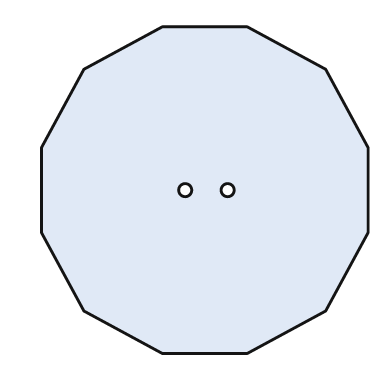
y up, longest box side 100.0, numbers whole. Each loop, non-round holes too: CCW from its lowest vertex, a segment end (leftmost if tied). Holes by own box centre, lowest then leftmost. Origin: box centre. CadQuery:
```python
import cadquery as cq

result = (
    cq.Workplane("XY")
    .moveTo(-13.0, -50.0)
    .lineTo(13.0, -50.0)
    .lineTo(37.0, -37.0)
    .lineTo(50.0, -13.0)
    .lineTo(50.0, 13.0)
    .lineTo(37.0, 37.0)
    .lineTo(13.0, 50.0)
    .lineTo(-13.0, 50.0)
    .lineTo(-37.0, 37.0)
    .lineTo(-50.0, 13.0)
    .lineTo(-50.0, -13.0)
    .lineTo(-37.0, -37.0)
    .close()
    .moveTo(-6.0, 0.0)
    .circle(2.0)
    .moveTo(7.0, 0.0)
    .circle(2.0)
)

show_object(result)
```